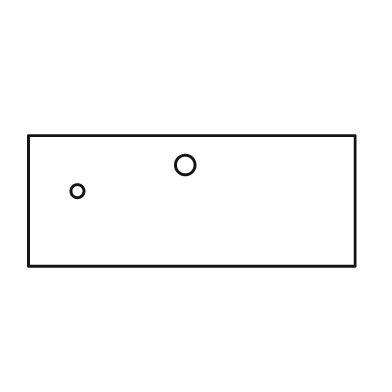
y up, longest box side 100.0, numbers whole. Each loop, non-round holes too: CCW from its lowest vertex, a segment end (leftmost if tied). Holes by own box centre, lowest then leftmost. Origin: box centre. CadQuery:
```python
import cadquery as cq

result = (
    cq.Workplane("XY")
    .moveTo(-50.0, -20.0)
    .lineTo(50.0, -20.0)
    .lineTo(50.0, 20.0)
    .lineTo(-50.0, 20.0)
    .close()
    .moveTo(-35.0, 3.0)
    .circle(2.0)
    .moveTo(-2.0, 11.0)
    .circle(3.0)
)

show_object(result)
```